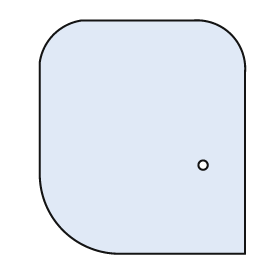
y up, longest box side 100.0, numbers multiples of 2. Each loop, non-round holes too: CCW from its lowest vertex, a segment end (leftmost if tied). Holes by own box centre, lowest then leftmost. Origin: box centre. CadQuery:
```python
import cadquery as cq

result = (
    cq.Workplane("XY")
    .moveTo(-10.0, -50.0)
    .lineTo(44.0, -50.0)
    .lineTo(44.0, 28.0)
    .threePointArc((38.0, 44.0), (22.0, 50.0))
    .lineTo(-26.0, 50.0)
    .threePointArc((-38.0, 44.0), (-44.0, 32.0))
    .lineTo(-44.0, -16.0)
    .threePointArc((-34.0, -40.0), (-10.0, -50.0))
    .close()
    .moveTo(26.0, -12.0)
    .circle(2.0)
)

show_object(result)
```